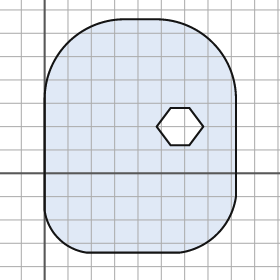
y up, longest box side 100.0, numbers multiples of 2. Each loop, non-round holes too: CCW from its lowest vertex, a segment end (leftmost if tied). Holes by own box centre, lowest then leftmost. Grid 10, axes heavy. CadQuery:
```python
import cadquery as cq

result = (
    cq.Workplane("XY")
    .moveTo(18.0, -34.0)
    .lineTo(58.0, -34.0)
    .threePointArc((74.0, -26.0), (82.0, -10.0))
    .lineTo(82.0, 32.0)
    .threePointArc((72.0, 56.0), (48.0, 66.0))
    .lineTo(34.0, 66.0)
    .threePointArc((10.0, 56.0), (0.0, 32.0))
    .lineTo(0.0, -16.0)
    .threePointArc((6.0, -28.0), (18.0, -34.0))
    .close()
    .moveTo(54.0, 12.0)
    .lineTo(62.0, 12.0)
    .lineTo(68.0, 20.0)
    .lineTo(62.0, 28.0)
    .lineTo(54.0, 28.0)
    .lineTo(48.0, 20.0)
    .close()
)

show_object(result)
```